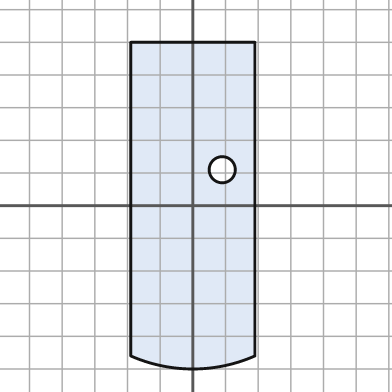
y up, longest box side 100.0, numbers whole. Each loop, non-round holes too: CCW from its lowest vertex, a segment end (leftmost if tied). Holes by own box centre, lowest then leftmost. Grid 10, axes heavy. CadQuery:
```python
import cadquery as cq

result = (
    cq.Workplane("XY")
    .moveTo(-19.0, -46.0)
    .threePointArc((0.0, -50.0), (19.0, -46.0))
    .lineTo(19.0, 50.0)
    .lineTo(-19.0, 50.0)
    .close()
    .moveTo(9.0, 11.0)
    .circle(4.0)
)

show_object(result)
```